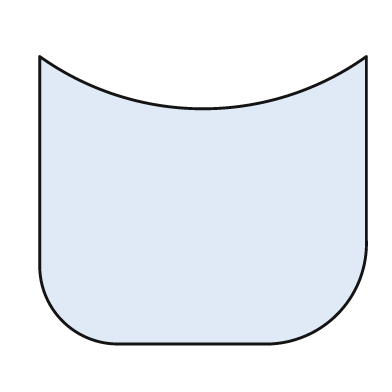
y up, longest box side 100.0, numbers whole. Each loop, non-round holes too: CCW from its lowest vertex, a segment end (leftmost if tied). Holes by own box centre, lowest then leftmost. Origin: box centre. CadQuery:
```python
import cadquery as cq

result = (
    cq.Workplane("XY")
    .moveTo(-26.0, -44.0)
    .lineTo(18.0, -44.0)
    .threePointArc((41.0, -35.0), (50.0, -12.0))
    .lineTo(50.0, 44.0)
    .threePointArc((0.0, 28.0), (-50.0, 44.0))
    .lineTo(-50.0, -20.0)
    .threePointArc((-43.0, -37.0), (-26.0, -44.0))
    .close()
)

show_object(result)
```